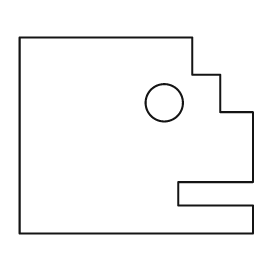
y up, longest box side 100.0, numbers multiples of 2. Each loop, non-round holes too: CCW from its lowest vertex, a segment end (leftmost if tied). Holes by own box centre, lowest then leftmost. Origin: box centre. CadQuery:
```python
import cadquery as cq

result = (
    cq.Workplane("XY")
    .moveTo(-50.0, -42.0)
    .lineTo(50.0, -42.0)
    .lineTo(50.0, -30.0)
    .lineTo(18.0, -30.0)
    .lineTo(18.0, -20.0)
    .lineTo(50.0, -20.0)
    .lineTo(50.0, 10.0)
    .lineTo(36.0, 10.0)
    .lineTo(36.0, 26.0)
    .lineTo(24.0, 26.0)
    .lineTo(24.0, 42.0)
    .lineTo(-50.0, 42.0)
    .close()
    .moveTo(12.0, 14.0)
    .circle(8.0)
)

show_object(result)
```